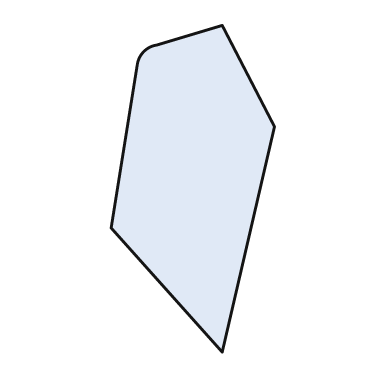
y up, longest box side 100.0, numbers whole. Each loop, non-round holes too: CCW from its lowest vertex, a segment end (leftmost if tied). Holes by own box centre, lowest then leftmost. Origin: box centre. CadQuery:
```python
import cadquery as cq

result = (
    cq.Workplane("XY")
    .moveTo(9.0, -50.0)
    .lineTo(25.0, 19.0)
    .lineTo(9.0, 50.0)
    .lineTo(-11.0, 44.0)
    .threePointArc((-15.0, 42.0), (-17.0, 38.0))
    .lineTo(-25.0, -12.0)
    .close()
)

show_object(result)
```